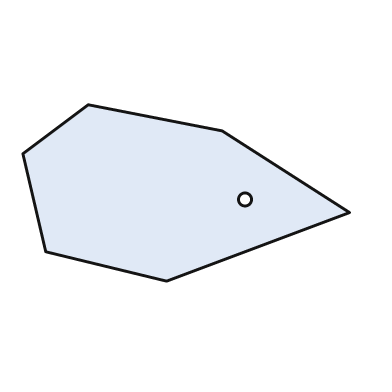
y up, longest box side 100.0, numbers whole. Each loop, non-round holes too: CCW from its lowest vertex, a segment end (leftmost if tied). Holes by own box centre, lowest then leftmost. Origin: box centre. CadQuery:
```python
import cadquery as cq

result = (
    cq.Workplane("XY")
    .moveTo(-6.0, -27.0)
    .lineTo(50.0, -6.0)
    .lineTo(11.0, 19.0)
    .lineTo(-30.0, 27.0)
    .lineTo(-50.0, 12.0)
    .lineTo(-43.0, -18.0)
    .close()
    .moveTo(18.0, -2.0)
    .circle(2.0)
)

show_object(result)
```